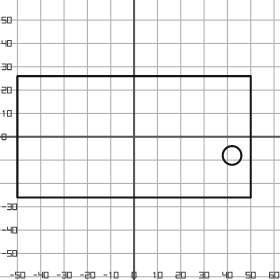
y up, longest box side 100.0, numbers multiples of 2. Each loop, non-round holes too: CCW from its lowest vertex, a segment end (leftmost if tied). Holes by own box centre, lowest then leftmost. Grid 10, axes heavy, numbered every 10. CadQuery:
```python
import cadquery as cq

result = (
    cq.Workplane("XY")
    .moveTo(-50.0, -26.0)
    .lineTo(50.0, -26.0)
    .lineTo(50.0, 26.0)
    .lineTo(-50.0, 26.0)
    .close()
    .moveTo(42.0, -8.0)
    .circle(4.0)
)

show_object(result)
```